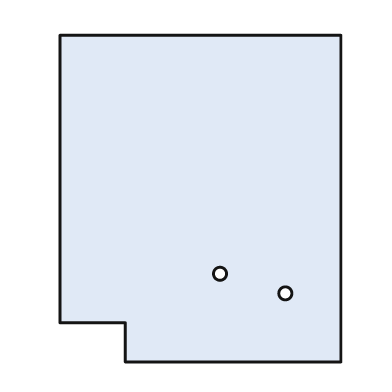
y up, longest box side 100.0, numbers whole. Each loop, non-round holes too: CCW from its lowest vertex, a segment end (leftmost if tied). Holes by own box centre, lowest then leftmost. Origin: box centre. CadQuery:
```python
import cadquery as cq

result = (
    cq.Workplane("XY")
    .moveTo(-23.0, -50.0)
    .lineTo(43.0, -50.0)
    .lineTo(43.0, 50.0)
    .lineTo(-43.0, 50.0)
    .lineTo(-43.0, -38.0)
    .lineTo(-23.0, -38.0)
    .close()
    .moveTo(26.0, -29.0)
    .circle(2.0)
    .moveTo(6.0, -23.0)
    .circle(2.0)
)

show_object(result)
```